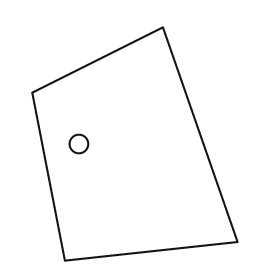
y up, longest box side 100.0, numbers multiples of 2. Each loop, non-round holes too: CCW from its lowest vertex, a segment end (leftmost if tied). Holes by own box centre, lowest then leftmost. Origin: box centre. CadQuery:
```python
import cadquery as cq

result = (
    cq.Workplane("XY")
    .moveTo(-30.0, -50.0)
    .lineTo(44.0, -42.0)
    .lineTo(12.0, 50.0)
    .lineTo(-44.0, 22.0)
    .close()
    .moveTo(-24.0, 0.0)
    .circle(4.0)
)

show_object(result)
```